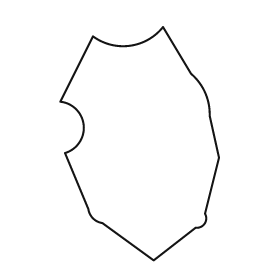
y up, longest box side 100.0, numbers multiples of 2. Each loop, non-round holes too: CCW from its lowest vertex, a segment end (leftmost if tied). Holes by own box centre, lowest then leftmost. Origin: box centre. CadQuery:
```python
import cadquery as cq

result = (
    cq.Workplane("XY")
    .moveTo(6.0, -50.0)
    .lineTo(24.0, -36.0)
    .threePointArc((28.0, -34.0), (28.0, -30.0))
    .lineTo(34.0, -6.0)
    .lineTo(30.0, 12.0)
    .threePointArc((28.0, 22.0), (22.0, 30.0))
    .lineTo(10.0, 50.0)
    .threePointArc((-4.0, 42.0), (-20.0, 46.0))
    .lineTo(-34.0, 18.0)
    .threePointArc((-24.0, 8.0), (-32.0, -4.0))
    .lineTo(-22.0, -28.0)
    .threePointArc((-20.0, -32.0), (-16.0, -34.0))
    .close()
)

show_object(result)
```